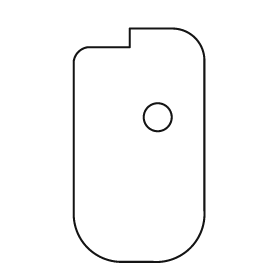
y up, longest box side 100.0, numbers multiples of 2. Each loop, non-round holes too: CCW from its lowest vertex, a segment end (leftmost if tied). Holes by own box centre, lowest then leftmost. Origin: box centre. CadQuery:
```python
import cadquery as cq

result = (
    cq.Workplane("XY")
    .moveTo(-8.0, -50.0)
    .lineTo(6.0, -50.0)
    .threePointArc((22.0, -44.0), (28.0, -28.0))
    .lineTo(28.0, 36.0)
    .threePointArc((24.0, 46.0), (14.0, 50.0))
    .lineTo(-4.0, 50.0)
    .lineTo(-4.0, 42.0)
    .lineTo(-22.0, 42.0)
    .threePointArc((-26.0, 40.0), (-28.0, 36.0))
    .lineTo(-28.0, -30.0)
    .threePointArc((-22.0, -44.0), (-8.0, -50.0))
    .close()
    .moveTo(8.0, 12.0)
    .circle(6.0)
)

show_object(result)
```